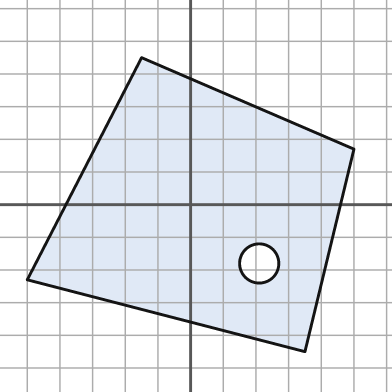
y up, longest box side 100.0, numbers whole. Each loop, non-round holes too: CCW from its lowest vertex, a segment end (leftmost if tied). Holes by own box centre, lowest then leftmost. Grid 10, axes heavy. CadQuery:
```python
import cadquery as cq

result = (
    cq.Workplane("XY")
    .moveTo(35.0, -45.0)
    .lineTo(50.0, 17.0)
    .lineTo(-15.0, 45.0)
    .lineTo(-50.0, -23.0)
    .close()
    .moveTo(21.0, -18.0)
    .circle(6.0)
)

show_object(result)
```